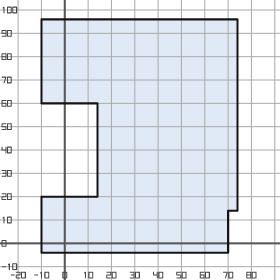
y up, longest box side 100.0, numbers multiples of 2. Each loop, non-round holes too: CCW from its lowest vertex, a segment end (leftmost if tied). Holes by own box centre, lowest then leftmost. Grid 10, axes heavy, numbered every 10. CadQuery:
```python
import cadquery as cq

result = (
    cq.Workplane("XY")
    .moveTo(-10.0, -4.0)
    .lineTo(70.0, -4.0)
    .lineTo(70.0, 14.0)
    .lineTo(74.0, 14.0)
    .lineTo(74.0, 96.0)
    .lineTo(-10.0, 96.0)
    .lineTo(-10.0, 60.0)
    .lineTo(14.0, 60.0)
    .lineTo(14.0, 20.0)
    .lineTo(-10.0, 20.0)
    .close()
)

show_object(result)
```